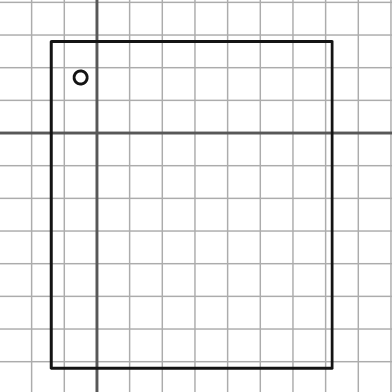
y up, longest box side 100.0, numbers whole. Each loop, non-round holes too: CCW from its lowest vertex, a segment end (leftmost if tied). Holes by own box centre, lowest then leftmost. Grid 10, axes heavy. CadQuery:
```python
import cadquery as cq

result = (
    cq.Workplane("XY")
    .moveTo(-14.0, -72.0)
    .lineTo(72.0, -72.0)
    .lineTo(72.0, 28.0)
    .lineTo(-14.0, 28.0)
    .close()
    .moveTo(-5.0, 17.0)
    .circle(2.0)
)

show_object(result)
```